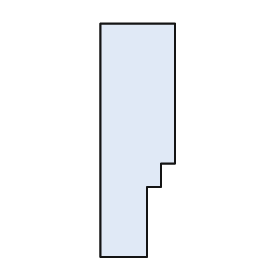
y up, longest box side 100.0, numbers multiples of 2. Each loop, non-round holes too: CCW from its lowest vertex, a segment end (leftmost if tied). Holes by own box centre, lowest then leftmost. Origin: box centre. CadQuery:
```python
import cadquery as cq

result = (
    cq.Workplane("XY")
    .moveTo(-16.0, -50.0)
    .lineTo(4.0, -50.0)
    .lineTo(4.0, -20.0)
    .lineTo(10.0, -20.0)
    .lineTo(10.0, -10.0)
    .lineTo(16.0, -10.0)
    .lineTo(16.0, 50.0)
    .lineTo(-16.0, 50.0)
    .close()
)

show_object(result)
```